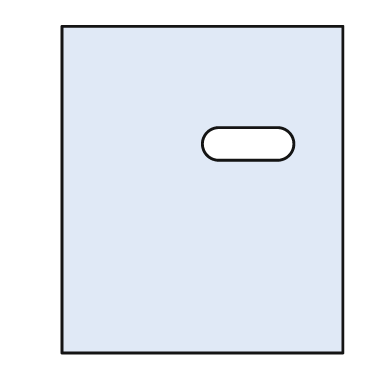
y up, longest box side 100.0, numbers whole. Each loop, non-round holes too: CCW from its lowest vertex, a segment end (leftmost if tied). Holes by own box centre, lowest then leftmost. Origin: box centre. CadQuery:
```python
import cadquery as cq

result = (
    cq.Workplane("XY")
    .moveTo(-43.0, -50.0)
    .lineTo(43.0, -50.0)
    .lineTo(43.0, 50.0)
    .lineTo(-43.0, 50.0)
    .close()
    .moveTo(5.0, 9.0)
    .lineTo(23.0, 9.0)
    .threePointArc((28.0, 14.0), (23.0, 19.0))
    .lineTo(5.0, 19.0)
    .threePointArc((0.0, 14.0), (5.0, 9.0))
    .close()
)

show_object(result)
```